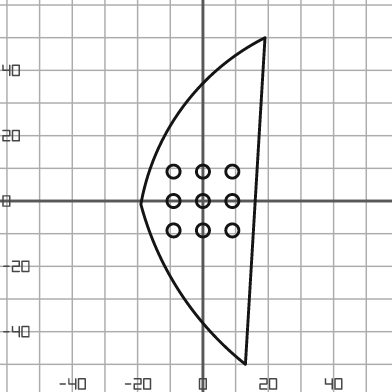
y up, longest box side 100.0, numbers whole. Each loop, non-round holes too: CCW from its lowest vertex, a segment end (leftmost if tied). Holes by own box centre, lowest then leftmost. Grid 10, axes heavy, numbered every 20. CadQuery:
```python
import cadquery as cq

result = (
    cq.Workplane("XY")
    .moveTo(13.0, -50.0)
    .lineTo(19.0, 50.0)
    .threePointArc((-6.0, 29.0), (-19.0, -1.0))
    .threePointArc((-7.0, -28.0), (13.0, -50.0))
    .close()
    .moveTo(-9.0, -9.0)
    .circle(2.0)
    .moveTo(0.0, -9.0)
    .circle(2.0)
    .moveTo(9.0, -9.0)
    .circle(2.0)
    .moveTo(-9.0, 0.0)
    .circle(2.0)
    .moveTo(0.0, 0.0)
    .circle(2.0)
    .moveTo(9.0, 0.0)
    .circle(2.0)
    .moveTo(-9.0, 9.0)
    .circle(2.0)
    .moveTo(0.0, 9.0)
    .circle(2.0)
    .moveTo(9.0, 9.0)
    .circle(2.0)
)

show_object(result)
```